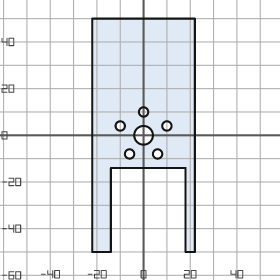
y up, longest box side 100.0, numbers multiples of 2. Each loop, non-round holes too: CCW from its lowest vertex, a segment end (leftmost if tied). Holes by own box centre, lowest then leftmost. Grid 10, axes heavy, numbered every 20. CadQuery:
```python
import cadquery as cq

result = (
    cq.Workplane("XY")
    .moveTo(-22.0, -50.0)
    .lineTo(-14.0, -50.0)
    .lineTo(-14.0, -14.0)
    .lineTo(18.0, -14.0)
    .lineTo(18.0, -50.0)
    .lineTo(22.0, -50.0)
    .lineTo(22.0, 50.0)
    .lineTo(-22.0, 50.0)
    .close()
    .moveTo(-6.0, -8.0)
    .circle(2.0)
    .moveTo(6.0, -8.0)
    .circle(2.0)
    .moveTo(0.0, 0.0)
    .circle(4.0)
    .moveTo(-10.0, 4.0)
    .circle(2.0)
    .moveTo(10.0, 4.0)
    .circle(2.0)
    .moveTo(0.0, 10.0)
    .circle(2.0)
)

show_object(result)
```